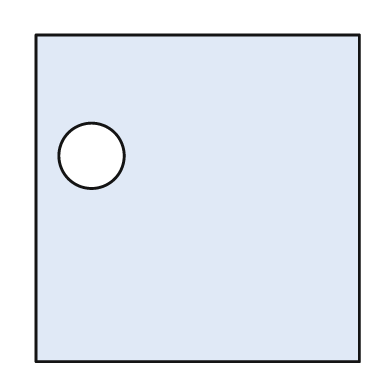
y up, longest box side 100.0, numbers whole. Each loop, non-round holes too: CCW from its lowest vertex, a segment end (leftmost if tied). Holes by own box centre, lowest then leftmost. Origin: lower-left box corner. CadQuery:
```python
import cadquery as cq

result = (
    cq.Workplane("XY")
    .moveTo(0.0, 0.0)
    .lineTo(99.0, 0.0)
    .lineTo(99.0, 100.0)
    .lineTo(0.0, 100.0)
    .close()
    .moveTo(17.0, 63.0)
    .circle(10.0)
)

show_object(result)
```